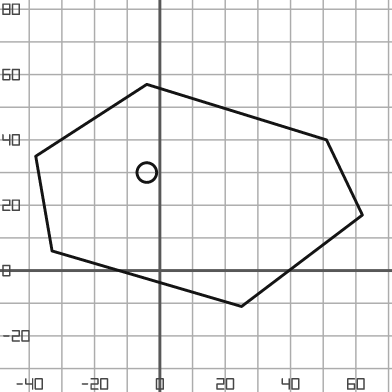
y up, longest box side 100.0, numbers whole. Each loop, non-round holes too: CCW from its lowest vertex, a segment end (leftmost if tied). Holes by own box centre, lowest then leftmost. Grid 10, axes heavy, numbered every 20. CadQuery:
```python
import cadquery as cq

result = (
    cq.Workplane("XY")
    .moveTo(25.0, -11.0)
    .lineTo(62.0, 17.0)
    .lineTo(51.0, 40.0)
    .lineTo(-4.0, 57.0)
    .lineTo(-38.0, 35.0)
    .lineTo(-33.0, 6.0)
    .close()
    .moveTo(-4.0, 30.0)
    .circle(3.0)
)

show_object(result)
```